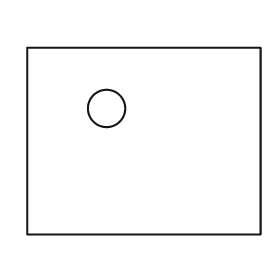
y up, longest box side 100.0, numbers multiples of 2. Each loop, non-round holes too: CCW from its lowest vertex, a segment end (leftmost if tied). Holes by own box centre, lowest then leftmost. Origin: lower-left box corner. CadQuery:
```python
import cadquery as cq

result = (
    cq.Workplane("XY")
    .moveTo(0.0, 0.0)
    .lineTo(100.0, 0.0)
    .lineTo(100.0, 80.0)
    .lineTo(0.0, 80.0)
    .close()
    .moveTo(34.0, 54.0)
    .circle(8.0)
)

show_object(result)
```